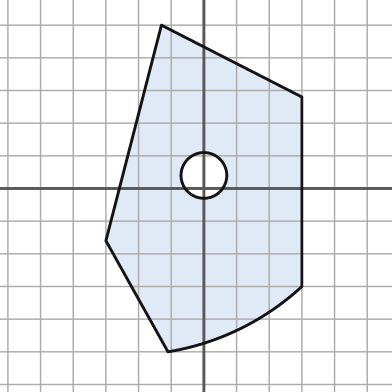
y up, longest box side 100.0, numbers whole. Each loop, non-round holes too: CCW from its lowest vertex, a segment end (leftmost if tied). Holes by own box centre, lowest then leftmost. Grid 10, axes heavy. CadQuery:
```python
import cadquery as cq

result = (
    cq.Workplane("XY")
    .moveTo(-11.0, -50.0)
    .threePointArc((11.0, -43.0), (30.0, -30.0))
    .lineTo(30.0, 28.0)
    .lineTo(-13.0, 50.0)
    .lineTo(-30.0, -16.0)
    .close()
    .moveTo(0.0, 4.0)
    .circle(7.0)
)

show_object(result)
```